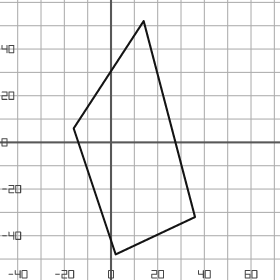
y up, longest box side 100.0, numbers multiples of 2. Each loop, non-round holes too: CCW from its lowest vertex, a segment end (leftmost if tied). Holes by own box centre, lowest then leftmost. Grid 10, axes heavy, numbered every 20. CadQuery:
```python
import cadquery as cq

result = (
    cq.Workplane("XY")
    .moveTo(2.0, -48.0)
    .lineTo(36.0, -32.0)
    .lineTo(14.0, 52.0)
    .lineTo(-16.0, 6.0)
    .close()
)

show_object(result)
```